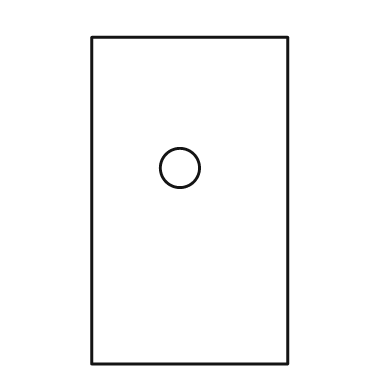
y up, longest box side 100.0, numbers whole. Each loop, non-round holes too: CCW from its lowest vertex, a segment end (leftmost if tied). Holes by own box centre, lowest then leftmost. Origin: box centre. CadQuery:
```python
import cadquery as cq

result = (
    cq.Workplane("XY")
    .moveTo(-30.0, -50.0)
    .lineTo(30.0, -50.0)
    .lineTo(30.0, 50.0)
    .lineTo(-30.0, 50.0)
    .close()
    .moveTo(-3.0, 10.0)
    .circle(6.0)
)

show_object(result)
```